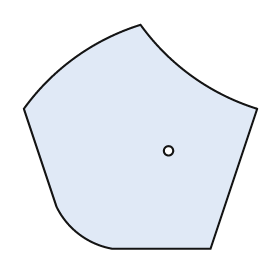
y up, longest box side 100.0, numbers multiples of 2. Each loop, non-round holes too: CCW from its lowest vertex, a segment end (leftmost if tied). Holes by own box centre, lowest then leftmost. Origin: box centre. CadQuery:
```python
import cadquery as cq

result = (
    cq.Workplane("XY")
    .moveTo(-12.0, -48.0)
    .lineTo(30.0, -48.0)
    .lineTo(50.0, 12.0)
    .threePointArc((22.0, 26.0), (0.0, 48.0))
    .threePointArc((-28.0, 34.0), (-50.0, 12.0))
    .lineTo(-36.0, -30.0)
    .threePointArc((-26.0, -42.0), (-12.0, -48.0))
    .close()
    .moveTo(12.0, -6.0)
    .circle(2.0)
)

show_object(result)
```